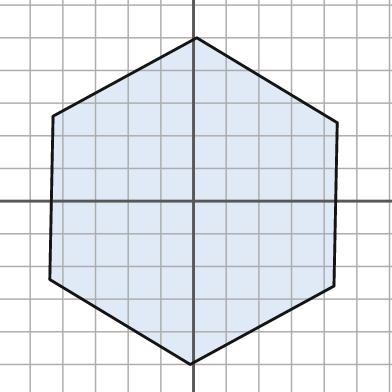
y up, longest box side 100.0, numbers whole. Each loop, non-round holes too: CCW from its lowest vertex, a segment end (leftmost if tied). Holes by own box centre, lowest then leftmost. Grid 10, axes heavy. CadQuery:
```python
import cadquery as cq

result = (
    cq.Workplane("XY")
    .moveTo(-1.0, -50.0)
    .lineTo(43.0, -26.0)
    .lineTo(44.0, 24.0)
    .lineTo(1.0, 50.0)
    .lineTo(-43.0, 26.0)
    .lineTo(-44.0, -24.0)
    .close()
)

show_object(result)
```